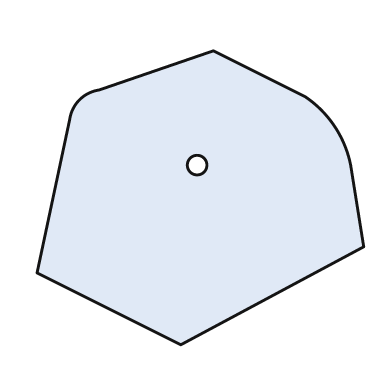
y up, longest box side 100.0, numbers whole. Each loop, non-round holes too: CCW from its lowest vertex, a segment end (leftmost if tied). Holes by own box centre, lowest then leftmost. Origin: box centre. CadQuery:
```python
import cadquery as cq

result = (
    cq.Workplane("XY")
    .moveTo(-6.0, -45.0)
    .lineTo(50.0, -15.0)
    .lineTo(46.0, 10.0)
    .threePointArc((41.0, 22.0), (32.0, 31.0))
    .lineTo(4.0, 45.0)
    .lineTo(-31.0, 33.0)
    .threePointArc((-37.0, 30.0), (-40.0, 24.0))
    .lineTo(-50.0, -23.0)
    .close()
    .moveTo(-1.0, 10.0)
    .circle(3.0)
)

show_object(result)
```